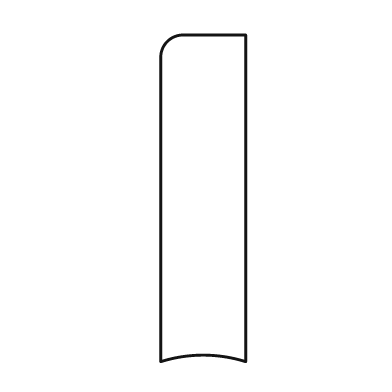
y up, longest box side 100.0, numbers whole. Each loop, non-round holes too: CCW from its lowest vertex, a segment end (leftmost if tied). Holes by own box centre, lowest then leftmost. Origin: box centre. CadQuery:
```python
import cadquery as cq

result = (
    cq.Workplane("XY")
    .moveTo(-13.0, -50.0)
    .threePointArc((0.0, -48.0), (13.0, -50.0))
    .lineTo(13.0, 50.0)
    .lineTo(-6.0, 50.0)
    .threePointArc((-11.0, 48.0), (-13.0, 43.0))
    .close()
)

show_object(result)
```